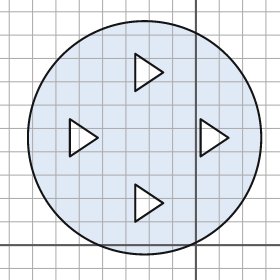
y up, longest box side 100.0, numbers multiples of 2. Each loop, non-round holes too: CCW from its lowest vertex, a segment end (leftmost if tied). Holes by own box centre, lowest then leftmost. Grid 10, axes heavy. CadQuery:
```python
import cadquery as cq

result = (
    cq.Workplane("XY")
    .moveTo(-22.0, 46.0)
    .circle(50.0)
    .moveTo(-26.0, 10.0)
    .lineTo(-14.0, 18.0)
    .lineTo(-26.0, 26.0)
    .close()
    .moveTo(-54.0, 38.0)
    .lineTo(-42.0, 46.0)
    .lineTo(-54.0, 54.0)
    .close()
    .moveTo(2.0, 38.0)
    .lineTo(14.0, 46.0)
    .lineTo(2.0, 54.0)
    .close()
    .moveTo(-26.0, 66.0)
    .lineTo(-14.0, 74.0)
    .lineTo(-26.0, 82.0)
    .close()
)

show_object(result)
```